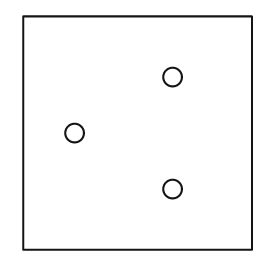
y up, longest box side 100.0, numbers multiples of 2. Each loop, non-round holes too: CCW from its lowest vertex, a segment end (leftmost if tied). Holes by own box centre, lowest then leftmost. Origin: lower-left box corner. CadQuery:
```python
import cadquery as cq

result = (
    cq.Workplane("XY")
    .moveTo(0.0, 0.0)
    .lineTo(98.0, 0.0)
    .lineTo(98.0, 100.0)
    .lineTo(0.0, 100.0)
    .close()
    .moveTo(64.0, 26.0)
    .circle(4.0)
    .moveTo(22.0, 50.0)
    .circle(4.0)
    .moveTo(64.0, 74.0)
    .circle(4.0)
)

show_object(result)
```